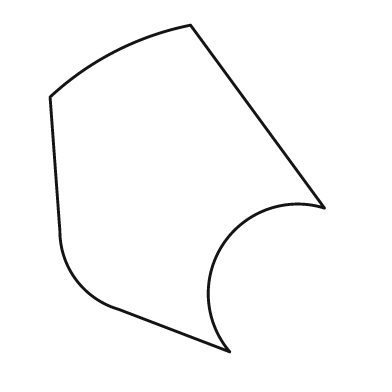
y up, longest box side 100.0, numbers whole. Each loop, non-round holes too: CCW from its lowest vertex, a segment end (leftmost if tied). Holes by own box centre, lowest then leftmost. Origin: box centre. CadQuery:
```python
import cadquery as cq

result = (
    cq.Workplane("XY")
    .moveTo(13.0, -50.0)
    .threePointArc((11.0, -17.0), (42.0, -6.0))
    .lineTo(1.0, 50.0)
    .threePointArc((-22.0, 42.0), (-42.0, 28.0))
    .lineTo(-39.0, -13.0)
    .threePointArc((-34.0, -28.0), (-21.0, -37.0))
    .close()
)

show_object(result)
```